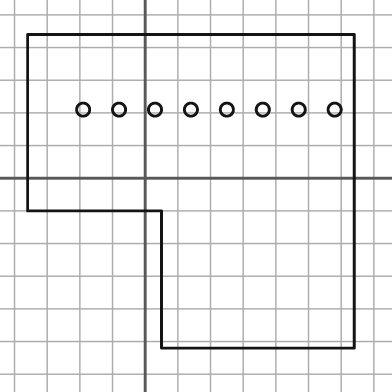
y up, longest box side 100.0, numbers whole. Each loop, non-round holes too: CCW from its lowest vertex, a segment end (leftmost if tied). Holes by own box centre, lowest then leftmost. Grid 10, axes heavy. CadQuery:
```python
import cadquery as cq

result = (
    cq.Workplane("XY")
    .moveTo(5.0, -52.0)
    .lineTo(64.0, -52.0)
    .lineTo(64.0, 44.0)
    .lineTo(-36.0, 44.0)
    .lineTo(-36.0, -10.0)
    .lineTo(5.0, -10.0)
    .close()
    .moveTo(-19.0, 21.0)
    .circle(2.0)
    .moveTo(-8.0, 21.0)
    .circle(2.0)
    .moveTo(3.0, 21.0)
    .circle(2.0)
    .moveTo(14.0, 21.0)
    .circle(2.0)
    .moveTo(25.0, 21.0)
    .circle(2.0)
    .moveTo(36.0, 21.0)
    .circle(2.0)
    .moveTo(47.0, 21.0)
    .circle(2.0)
    .moveTo(58.0, 21.0)
    .circle(2.0)
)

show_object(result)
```